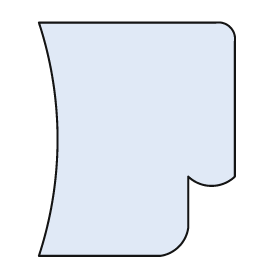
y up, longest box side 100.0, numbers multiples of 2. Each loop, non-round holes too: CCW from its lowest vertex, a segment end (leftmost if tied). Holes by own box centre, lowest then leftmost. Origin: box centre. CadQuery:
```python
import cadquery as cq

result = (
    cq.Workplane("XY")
    .moveTo(-42.0, -50.0)
    .lineTo(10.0, -50.0)
    .threePointArc((18.0, -46.0), (22.0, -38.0))
    .lineTo(22.0, -16.0)
    .threePointArc((32.0, -20.0), (42.0, -16.0))
    .lineTo(42.0, 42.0)
    .threePointArc((40.0, 48.0), (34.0, 50.0))
    .lineTo(-42.0, 50.0)
    .threePointArc((-34.0, 0.0), (-42.0, -50.0))
    .close()
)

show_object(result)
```